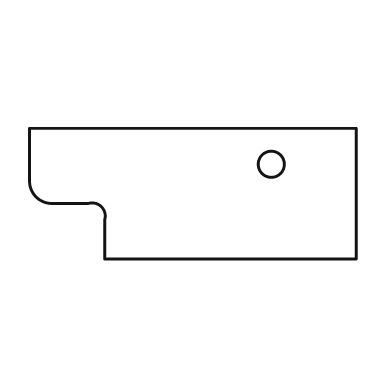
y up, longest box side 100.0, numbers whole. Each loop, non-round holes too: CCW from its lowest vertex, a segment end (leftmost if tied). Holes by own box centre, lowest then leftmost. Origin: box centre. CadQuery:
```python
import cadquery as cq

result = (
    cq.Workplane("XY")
    .moveTo(-27.0, -20.0)
    .lineTo(50.0, -20.0)
    .lineTo(50.0, 20.0)
    .lineTo(-50.0, 20.0)
    .lineTo(-50.0, 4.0)
    .threePointArc((-48.0, -1.0), (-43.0, -3.0))
    .lineTo(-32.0, -3.0)
    .threePointArc((-28.0, -4.0), (-27.0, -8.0))
    .close()
    .moveTo(24.0, 9.0)
    .circle(4.0)
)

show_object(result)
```